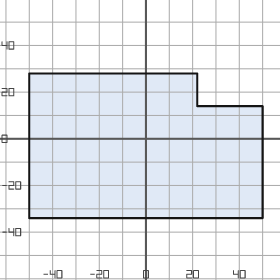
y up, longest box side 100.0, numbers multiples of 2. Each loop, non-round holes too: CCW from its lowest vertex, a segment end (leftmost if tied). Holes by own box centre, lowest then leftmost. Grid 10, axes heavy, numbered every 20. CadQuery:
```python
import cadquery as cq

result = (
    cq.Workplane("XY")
    .moveTo(-50.0, -34.0)
    .lineTo(50.0, -34.0)
    .lineTo(50.0, 14.0)
    .lineTo(22.0, 14.0)
    .lineTo(22.0, 28.0)
    .lineTo(-50.0, 28.0)
    .close()
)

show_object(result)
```